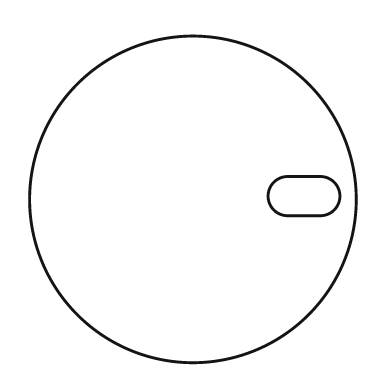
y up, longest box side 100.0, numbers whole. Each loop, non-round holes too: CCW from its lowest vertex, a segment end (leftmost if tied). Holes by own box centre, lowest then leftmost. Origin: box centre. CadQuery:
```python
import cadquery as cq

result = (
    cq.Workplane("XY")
    .moveTo(0.0, 0.0)
    .circle(50.0)
    .moveTo(29.0, -5.0)
    .lineTo(39.0, -5.0)
    .threePointArc((45.0, 1.0), (39.0, 7.0))
    .lineTo(29.0, 7.0)
    .threePointArc((23.0, 1.0), (29.0, -5.0))
    .close()
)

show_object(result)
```